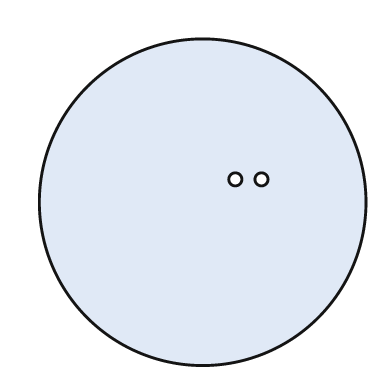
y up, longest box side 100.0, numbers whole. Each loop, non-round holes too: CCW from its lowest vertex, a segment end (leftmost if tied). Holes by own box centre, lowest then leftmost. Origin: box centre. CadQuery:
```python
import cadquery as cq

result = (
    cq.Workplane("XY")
    .moveTo(0.0, 0.0)
    .circle(50.0)
    .moveTo(10.0, 7.0)
    .circle(2.0)
    .moveTo(18.0, 7.0)
    .circle(2.0)
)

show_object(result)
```